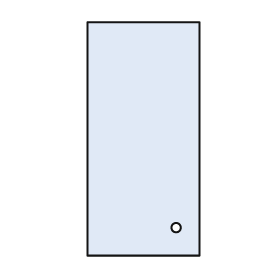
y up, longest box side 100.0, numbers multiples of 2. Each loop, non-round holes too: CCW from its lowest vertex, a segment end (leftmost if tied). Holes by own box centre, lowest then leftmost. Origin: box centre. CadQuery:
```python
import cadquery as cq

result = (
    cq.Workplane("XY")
    .moveTo(-24.0, -50.0)
    .lineTo(24.0, -50.0)
    .lineTo(24.0, 50.0)
    .lineTo(-24.0, 50.0)
    .close()
    .moveTo(14.0, -38.0)
    .circle(2.0)
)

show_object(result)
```